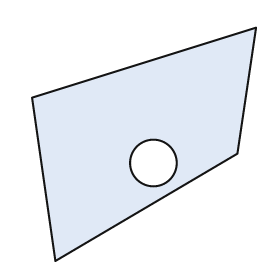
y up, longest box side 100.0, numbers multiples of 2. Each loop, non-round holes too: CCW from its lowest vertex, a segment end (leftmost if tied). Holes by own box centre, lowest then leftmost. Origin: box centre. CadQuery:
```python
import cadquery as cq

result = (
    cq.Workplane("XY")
    .moveTo(-38.0, -50.0)
    .lineTo(40.0, -4.0)
    .lineTo(48.0, 50.0)
    .lineTo(-48.0, 20.0)
    .close()
    .moveTo(4.0, -8.0)
    .circle(10.0)
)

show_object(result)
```